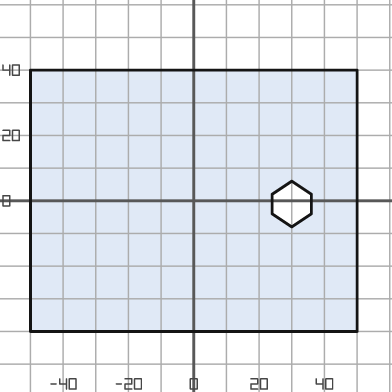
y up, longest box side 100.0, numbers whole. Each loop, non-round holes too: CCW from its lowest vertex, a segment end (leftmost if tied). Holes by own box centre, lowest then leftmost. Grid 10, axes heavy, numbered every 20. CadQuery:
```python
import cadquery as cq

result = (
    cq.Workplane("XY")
    .moveTo(-50.0, -40.0)
    .lineTo(50.0, -40.0)
    .lineTo(50.0, 40.0)
    .lineTo(-50.0, 40.0)
    .close()
    .moveTo(30.0, -8.0)
    .lineTo(36.0, -4.0)
    .lineTo(36.0, 2.0)
    .lineTo(30.0, 6.0)
    .lineTo(24.0, 2.0)
    .lineTo(24.0, -4.0)
    .close()
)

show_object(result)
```